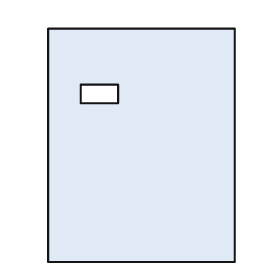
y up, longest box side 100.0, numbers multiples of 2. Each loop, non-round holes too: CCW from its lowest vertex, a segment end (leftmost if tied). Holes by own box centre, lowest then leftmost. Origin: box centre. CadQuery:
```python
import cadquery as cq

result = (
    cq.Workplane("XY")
    .moveTo(-40.0, -50.0)
    .lineTo(40.0, -50.0)
    .lineTo(40.0, 50.0)
    .lineTo(-40.0, 50.0)
    .close()
    .moveTo(-26.0, 18.0)
    .lineTo(-10.0, 18.0)
    .lineTo(-10.0, 26.0)
    .lineTo(-26.0, 26.0)
    .close()
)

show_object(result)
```